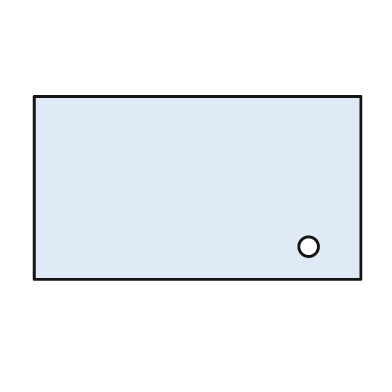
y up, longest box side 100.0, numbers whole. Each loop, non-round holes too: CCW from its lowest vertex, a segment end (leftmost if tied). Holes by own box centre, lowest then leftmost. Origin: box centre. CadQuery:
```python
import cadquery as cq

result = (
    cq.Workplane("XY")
    .moveTo(-50.0, -28.0)
    .lineTo(50.0, -28.0)
    .lineTo(50.0, 28.0)
    .lineTo(-50.0, 28.0)
    .close()
    .moveTo(34.0, -18.0)
    .circle(3.0)
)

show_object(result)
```